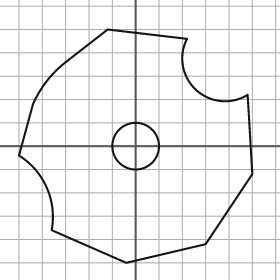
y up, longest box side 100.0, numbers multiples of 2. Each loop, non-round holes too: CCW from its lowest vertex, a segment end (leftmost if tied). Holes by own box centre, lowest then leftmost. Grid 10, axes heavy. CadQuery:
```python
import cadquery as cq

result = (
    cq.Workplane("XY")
    .moveTo(-4.0, -50.0)
    .lineTo(30.0, -42.0)
    .lineTo(50.0, -12.0)
    .lineTo(48.0, 22.0)
    .threePointArc((26.0, 24.0), (22.0, 46.0))
    .lineTo(-12.0, 50.0)
    .lineTo(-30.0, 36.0)
    .threePointArc((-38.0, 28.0), (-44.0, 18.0))
    .lineTo(-50.0, -4.0)
    .threePointArc((-38.0, -18.0), (-36.0, -36.0))
    .close()
    .moveTo(0.0, 0.0)
    .circle(10.0)
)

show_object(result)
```